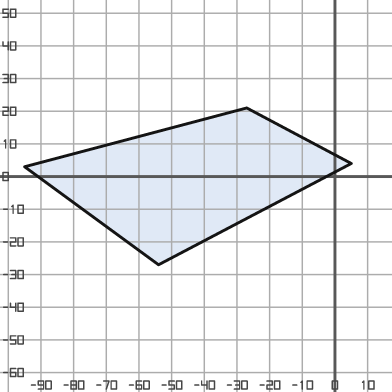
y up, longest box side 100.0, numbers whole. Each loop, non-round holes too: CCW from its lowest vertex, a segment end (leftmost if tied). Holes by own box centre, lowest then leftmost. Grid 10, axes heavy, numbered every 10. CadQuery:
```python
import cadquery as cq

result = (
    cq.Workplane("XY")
    .moveTo(-54.0, -27.0)
    .lineTo(5.0, 4.0)
    .lineTo(-27.0, 21.0)
    .lineTo(-95.0, 3.0)
    .close()
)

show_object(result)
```